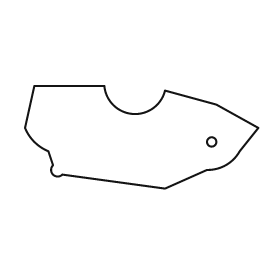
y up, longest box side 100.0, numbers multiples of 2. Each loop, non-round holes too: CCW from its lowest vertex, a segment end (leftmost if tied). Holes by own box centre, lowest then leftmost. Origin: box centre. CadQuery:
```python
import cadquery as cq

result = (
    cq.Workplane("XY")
    .moveTo(10.0, -22.0)
    .lineTo(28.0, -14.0)
    .threePointArc((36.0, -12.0), (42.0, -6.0))
    .lineTo(50.0, 4.0)
    .lineTo(32.0, 14.0)
    .lineTo(10.0, 20.0)
    .threePointArc((-4.0, 10.0), (-16.0, 22.0))
    .lineTo(-46.0, 22.0)
    .lineTo(-50.0, 4.0)
    .threePointArc((-46.0, -2.0), (-40.0, -6.0))
    .lineTo(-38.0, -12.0)
    .threePointArc((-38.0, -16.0), (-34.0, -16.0))
    .close()
    .moveTo(30.0, -2.0)
    .circle(2.0)
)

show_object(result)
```